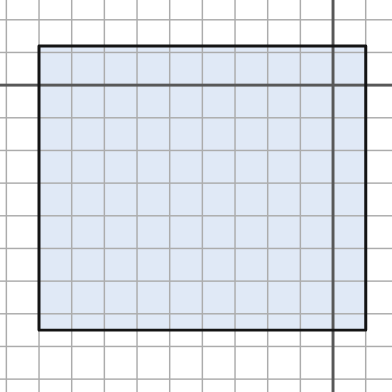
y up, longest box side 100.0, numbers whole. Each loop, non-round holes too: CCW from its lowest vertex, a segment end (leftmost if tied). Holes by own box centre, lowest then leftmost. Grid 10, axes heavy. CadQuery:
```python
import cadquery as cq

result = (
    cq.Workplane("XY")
    .moveTo(-90.0, -75.0)
    .lineTo(10.0, -75.0)
    .lineTo(10.0, 12.0)
    .lineTo(-90.0, 12.0)
    .close()
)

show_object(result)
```